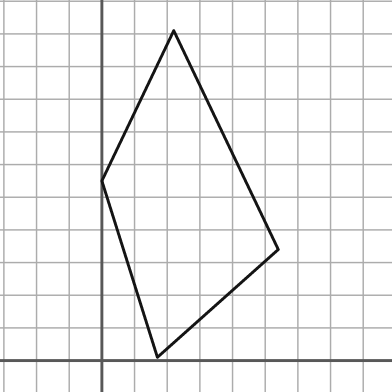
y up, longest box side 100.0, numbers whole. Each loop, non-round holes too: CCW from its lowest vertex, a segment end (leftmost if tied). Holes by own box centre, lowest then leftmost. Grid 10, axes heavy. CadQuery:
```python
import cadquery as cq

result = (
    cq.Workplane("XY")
    .moveTo(17.0, 1.0)
    .lineTo(54.0, 34.0)
    .lineTo(22.0, 101.0)
    .lineTo(0.0, 55.0)
    .close()
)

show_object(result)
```